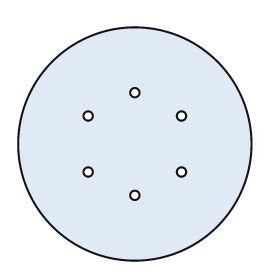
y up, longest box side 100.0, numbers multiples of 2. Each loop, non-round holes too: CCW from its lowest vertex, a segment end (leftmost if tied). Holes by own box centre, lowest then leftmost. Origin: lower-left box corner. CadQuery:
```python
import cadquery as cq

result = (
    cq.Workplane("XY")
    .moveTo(50.0, 50.0)
    .circle(50.0)
    .moveTo(50.0, 28.0)
    .circle(2.0)
    .moveTo(30.0, 38.0)
    .circle(2.0)
    .moveTo(70.0, 38.0)
    .circle(2.0)
    .moveTo(30.0, 62.0)
    .circle(2.0)
    .moveTo(70.0, 62.0)
    .circle(2.0)
    .moveTo(50.0, 72.0)
    .circle(2.0)
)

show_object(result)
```